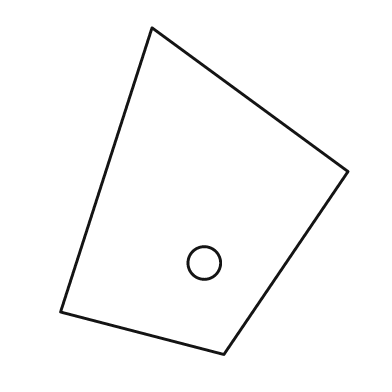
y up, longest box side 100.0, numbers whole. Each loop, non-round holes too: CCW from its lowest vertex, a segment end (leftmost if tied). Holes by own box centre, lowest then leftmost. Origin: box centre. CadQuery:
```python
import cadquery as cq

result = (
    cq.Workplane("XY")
    .moveTo(6.0, -50.0)
    .lineTo(44.0, 6.0)
    .lineTo(-16.0, 50.0)
    .lineTo(-44.0, -37.0)
    .close()
    .moveTo(0.0, -22.0)
    .circle(5.0)
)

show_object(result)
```